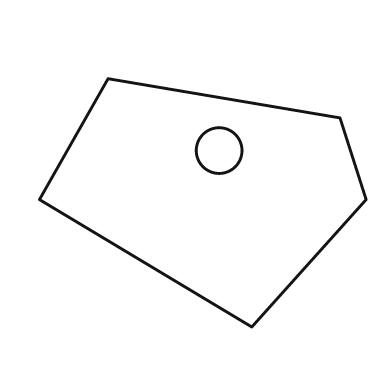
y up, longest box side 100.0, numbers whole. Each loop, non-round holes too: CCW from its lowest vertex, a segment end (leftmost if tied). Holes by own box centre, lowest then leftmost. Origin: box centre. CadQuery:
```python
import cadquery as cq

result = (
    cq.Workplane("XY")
    .moveTo(15.0, -38.0)
    .lineTo(50.0, 1.0)
    .lineTo(42.0, 26.0)
    .lineTo(-29.0, 38.0)
    .lineTo(-50.0, 1.0)
    .close()
    .moveTo(5.0, 16.0)
    .circle(7.0)
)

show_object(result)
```